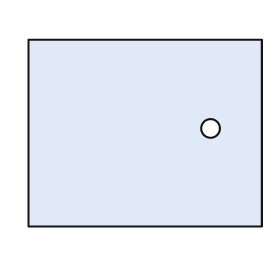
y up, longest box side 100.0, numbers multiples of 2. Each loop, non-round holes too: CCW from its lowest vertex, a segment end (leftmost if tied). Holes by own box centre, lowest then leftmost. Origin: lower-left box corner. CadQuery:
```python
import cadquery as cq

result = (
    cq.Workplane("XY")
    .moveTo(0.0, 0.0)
    .lineTo(100.0, 0.0)
    .lineTo(100.0, 80.0)
    .lineTo(0.0, 80.0)
    .close()
    .moveTo(78.0, 42.0)
    .circle(4.0)
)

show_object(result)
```